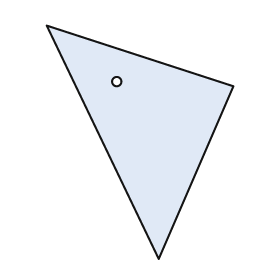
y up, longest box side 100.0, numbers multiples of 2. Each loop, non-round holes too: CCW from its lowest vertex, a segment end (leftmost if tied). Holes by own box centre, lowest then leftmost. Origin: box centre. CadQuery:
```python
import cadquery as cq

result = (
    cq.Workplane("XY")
    .moveTo(8.0, -50.0)
    .lineTo(40.0, 24.0)
    .lineTo(-40.0, 50.0)
    .close()
    .moveTo(-10.0, 26.0)
    .circle(2.0)
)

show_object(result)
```